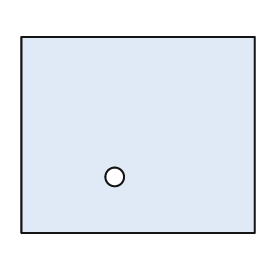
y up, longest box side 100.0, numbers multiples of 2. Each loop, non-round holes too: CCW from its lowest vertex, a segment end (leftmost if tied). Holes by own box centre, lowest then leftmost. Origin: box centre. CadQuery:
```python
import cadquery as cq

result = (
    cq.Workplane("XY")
    .moveTo(-50.0, -42.0)
    .lineTo(50.0, -42.0)
    .lineTo(50.0, 42.0)
    .lineTo(-50.0, 42.0)
    .close()
    .moveTo(-10.0, -18.0)
    .circle(4.0)
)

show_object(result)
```